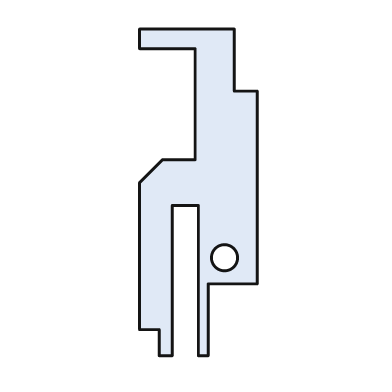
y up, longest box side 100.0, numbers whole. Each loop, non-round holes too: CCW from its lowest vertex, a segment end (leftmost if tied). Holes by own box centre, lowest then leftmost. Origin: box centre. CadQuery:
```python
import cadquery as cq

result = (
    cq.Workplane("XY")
    .moveTo(-12.0, -50.0)
    .lineTo(-8.0, -50.0)
    .lineTo(-8.0, -4.0)
    .lineTo(0.0, -4.0)
    .lineTo(0.0, -50.0)
    .lineTo(3.0, -50.0)
    .lineTo(3.0, -28.0)
    .lineTo(18.0, -28.0)
    .lineTo(18.0, 31.0)
    .lineTo(11.0, 31.0)
    .lineTo(11.0, 50.0)
    .lineTo(-18.0, 50.0)
    .lineTo(-18.0, 44.0)
    .lineTo(-1.0, 44.0)
    .lineTo(-1.0, 10.0)
    .lineTo(-11.0, 10.0)
    .lineTo(-18.0, 3.0)
    .lineTo(-18.0, -42.0)
    .lineTo(-12.0, -42.0)
    .close()
    .moveTo(8.0, -20.0)
    .circle(4.0)
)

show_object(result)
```